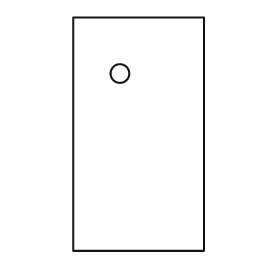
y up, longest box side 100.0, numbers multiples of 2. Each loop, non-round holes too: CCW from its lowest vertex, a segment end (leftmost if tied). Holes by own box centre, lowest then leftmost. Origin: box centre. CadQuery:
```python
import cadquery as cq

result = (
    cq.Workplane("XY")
    .moveTo(-28.0, -50.0)
    .lineTo(28.0, -50.0)
    .lineTo(28.0, 50.0)
    .lineTo(-28.0, 50.0)
    .close()
    .moveTo(-8.0, 26.0)
    .circle(4.0)
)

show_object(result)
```